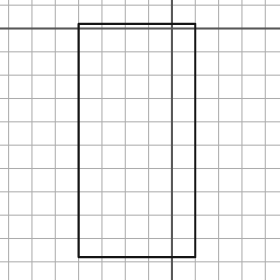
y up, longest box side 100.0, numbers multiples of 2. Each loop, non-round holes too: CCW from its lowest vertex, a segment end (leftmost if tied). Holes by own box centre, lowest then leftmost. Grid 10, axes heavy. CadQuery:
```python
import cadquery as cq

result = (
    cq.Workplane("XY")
    .moveTo(-40.0, -98.0)
    .lineTo(10.0, -98.0)
    .lineTo(10.0, 2.0)
    .lineTo(-40.0, 2.0)
    .close()
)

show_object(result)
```